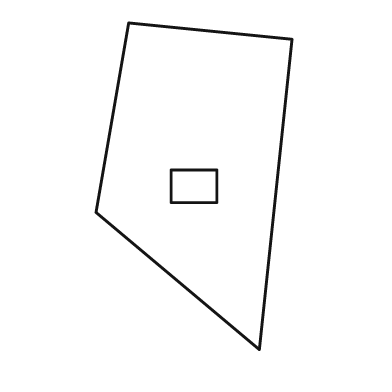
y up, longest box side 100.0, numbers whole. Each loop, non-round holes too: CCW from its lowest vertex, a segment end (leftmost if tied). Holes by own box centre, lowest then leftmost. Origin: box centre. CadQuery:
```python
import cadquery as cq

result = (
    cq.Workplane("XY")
    .moveTo(20.0, -50.0)
    .lineTo(30.0, 45.0)
    .lineTo(-20.0, 50.0)
    .lineTo(-30.0, -8.0)
    .close()
    .moveTo(-7.0, -5.0)
    .lineTo(7.0, -5.0)
    .lineTo(7.0, 5.0)
    .lineTo(-7.0, 5.0)
    .close()
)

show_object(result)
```